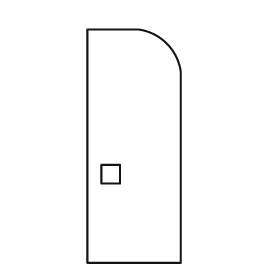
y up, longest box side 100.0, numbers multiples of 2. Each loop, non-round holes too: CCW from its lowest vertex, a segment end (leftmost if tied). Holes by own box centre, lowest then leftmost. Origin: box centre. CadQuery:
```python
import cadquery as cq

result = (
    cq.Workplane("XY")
    .moveTo(-20.0, -50.0)
    .lineTo(20.0, -50.0)
    .lineTo(20.0, 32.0)
    .threePointArc((14.0, 44.0), (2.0, 50.0))
    .lineTo(-20.0, 50.0)
    .close()
    .moveTo(-14.0, -16.0)
    .lineTo(-6.0, -16.0)
    .lineTo(-6.0, -8.0)
    .lineTo(-14.0, -8.0)
    .close()
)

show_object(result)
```